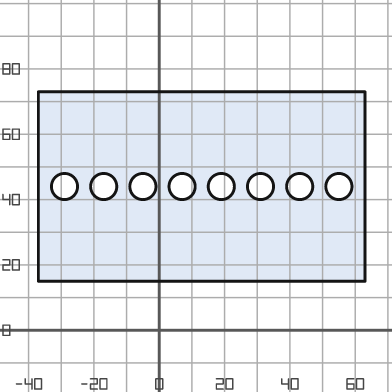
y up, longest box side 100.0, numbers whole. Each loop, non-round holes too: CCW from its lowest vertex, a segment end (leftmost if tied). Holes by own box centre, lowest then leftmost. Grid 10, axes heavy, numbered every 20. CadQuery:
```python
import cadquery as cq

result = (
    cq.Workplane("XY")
    .moveTo(-37.0, 15.0)
    .lineTo(63.0, 15.0)
    .lineTo(63.0, 73.0)
    .lineTo(-37.0, 73.0)
    .close()
    .moveTo(-29.0, 44.0)
    .circle(4.0)
    .moveTo(-17.0, 44.0)
    .circle(4.0)
    .moveTo(-5.0, 44.0)
    .circle(4.0)
    .moveTo(7.0, 44.0)
    .circle(4.0)
    .moveTo(19.0, 44.0)
    .circle(4.0)
    .moveTo(31.0, 44.0)
    .circle(4.0)
    .moveTo(43.0, 44.0)
    .circle(4.0)
    .moveTo(55.0, 44.0)
    .circle(4.0)
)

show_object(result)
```